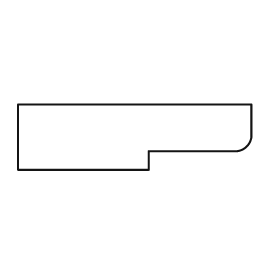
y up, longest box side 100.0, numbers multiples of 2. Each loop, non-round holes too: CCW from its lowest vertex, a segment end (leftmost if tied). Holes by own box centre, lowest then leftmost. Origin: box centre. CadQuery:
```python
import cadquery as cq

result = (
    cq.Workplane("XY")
    .moveTo(-50.0, -14.0)
    .lineTo(6.0, -14.0)
    .lineTo(6.0, -6.0)
    .lineTo(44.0, -6.0)
    .threePointArc((48.0, -4.0), (50.0, 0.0))
    .lineTo(50.0, 14.0)
    .lineTo(-50.0, 14.0)
    .close()
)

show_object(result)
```